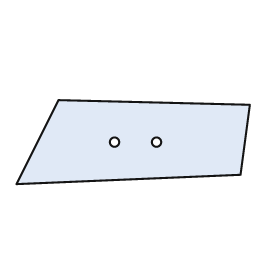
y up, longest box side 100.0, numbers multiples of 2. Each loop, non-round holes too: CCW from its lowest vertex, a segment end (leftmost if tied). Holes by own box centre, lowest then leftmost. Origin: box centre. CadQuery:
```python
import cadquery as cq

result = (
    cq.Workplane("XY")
    .moveTo(-50.0, -18.0)
    .lineTo(46.0, -14.0)
    .lineTo(50.0, 16.0)
    .lineTo(-32.0, 18.0)
    .close()
    .moveTo(-8.0, 0.0)
    .circle(2.0)
    .moveTo(10.0, 0.0)
    .circle(2.0)
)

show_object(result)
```